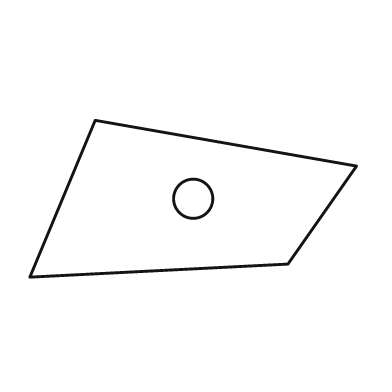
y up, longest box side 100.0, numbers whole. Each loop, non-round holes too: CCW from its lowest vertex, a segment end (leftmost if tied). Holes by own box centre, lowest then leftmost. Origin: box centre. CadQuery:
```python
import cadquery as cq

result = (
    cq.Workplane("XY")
    .moveTo(-50.0, -24.0)
    .lineTo(29.0, -20.0)
    .lineTo(50.0, 10.0)
    .lineTo(-30.0, 24.0)
    .close()
    .moveTo(0.0, 0.0)
    .circle(6.0)
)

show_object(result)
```